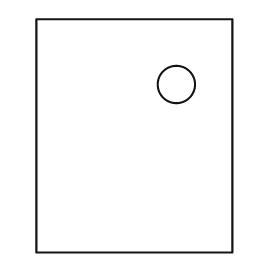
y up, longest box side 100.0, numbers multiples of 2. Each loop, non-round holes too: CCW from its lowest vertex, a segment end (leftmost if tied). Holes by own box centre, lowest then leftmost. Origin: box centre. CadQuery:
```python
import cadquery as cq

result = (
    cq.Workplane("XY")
    .moveTo(-42.0, -50.0)
    .lineTo(42.0, -50.0)
    .lineTo(42.0, 50.0)
    .lineTo(-42.0, 50.0)
    .close()
    .moveTo(18.0, 22.0)
    .circle(8.0)
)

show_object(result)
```